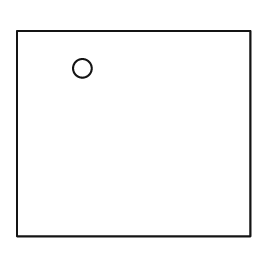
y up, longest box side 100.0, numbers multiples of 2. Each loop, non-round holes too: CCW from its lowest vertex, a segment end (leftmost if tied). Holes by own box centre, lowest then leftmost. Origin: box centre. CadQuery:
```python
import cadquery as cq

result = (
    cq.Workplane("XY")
    .moveTo(-50.0, -44.0)
    .lineTo(50.0, -44.0)
    .lineTo(50.0, 44.0)
    .lineTo(-50.0, 44.0)
    .close()
    .moveTo(-22.0, 28.0)
    .circle(4.0)
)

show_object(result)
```